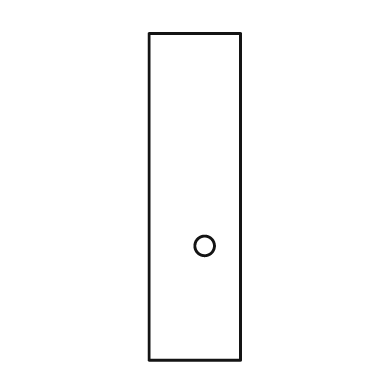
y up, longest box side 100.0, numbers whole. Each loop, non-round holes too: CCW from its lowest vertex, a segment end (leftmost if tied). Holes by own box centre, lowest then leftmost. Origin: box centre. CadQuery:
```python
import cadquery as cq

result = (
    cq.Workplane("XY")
    .moveTo(-14.0, -50.0)
    .lineTo(14.0, -50.0)
    .lineTo(14.0, 50.0)
    .lineTo(-14.0, 50.0)
    .close()
    .moveTo(3.0, -15.0)
    .circle(3.0)
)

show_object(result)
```